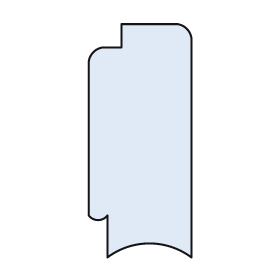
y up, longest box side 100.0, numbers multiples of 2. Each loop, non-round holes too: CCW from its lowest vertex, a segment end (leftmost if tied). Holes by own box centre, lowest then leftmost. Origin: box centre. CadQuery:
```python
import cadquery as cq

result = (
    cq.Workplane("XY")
    .moveTo(-14.0, -50.0)
    .threePointArc((4.0, -44.0), (22.0, -50.0))
    .lineTo(22.0, 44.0)
    .threePointArc((20.0, 48.0), (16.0, 50.0))
    .lineTo(-8.0, 50.0)
    .lineTo(-8.0, 40.0)
    .lineTo(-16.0, 40.0)
    .threePointArc((-20.0, 38.0), (-22.0, 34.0))
    .lineTo(-22.0, -32.0)
    .threePointArc((-18.0, -34.0), (-14.0, -32.0))
    .close()
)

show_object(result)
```